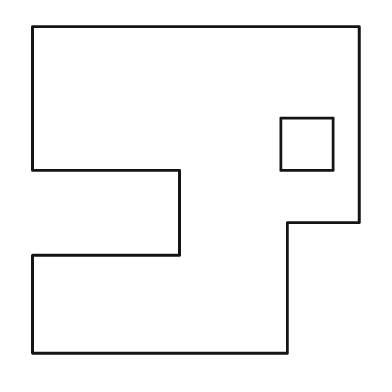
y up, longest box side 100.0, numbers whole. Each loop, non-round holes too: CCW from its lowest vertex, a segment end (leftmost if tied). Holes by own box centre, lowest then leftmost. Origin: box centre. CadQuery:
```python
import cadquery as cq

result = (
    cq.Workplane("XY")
    .moveTo(-50.0, -50.0)
    .lineTo(28.0, -50.0)
    .lineTo(28.0, -10.0)
    .lineTo(50.0, -10.0)
    .lineTo(50.0, 50.0)
    .lineTo(-50.0, 50.0)
    .lineTo(-50.0, 6.0)
    .lineTo(-5.0, 6.0)
    .lineTo(-5.0, -20.0)
    .lineTo(-50.0, -20.0)
    .close()
    .moveTo(26.0, 6.0)
    .lineTo(42.0, 6.0)
    .lineTo(42.0, 22.0)
    .lineTo(26.0, 22.0)
    .close()
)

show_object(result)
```